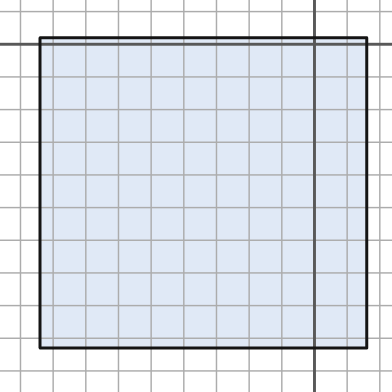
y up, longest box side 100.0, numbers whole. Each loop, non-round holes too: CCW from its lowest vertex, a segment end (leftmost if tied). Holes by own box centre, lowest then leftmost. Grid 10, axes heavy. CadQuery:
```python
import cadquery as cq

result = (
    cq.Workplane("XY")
    .moveTo(-84.0, -93.0)
    .lineTo(16.0, -93.0)
    .lineTo(16.0, 2.0)
    .lineTo(-84.0, 2.0)
    .close()
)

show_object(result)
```